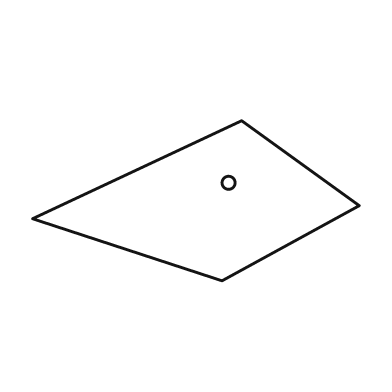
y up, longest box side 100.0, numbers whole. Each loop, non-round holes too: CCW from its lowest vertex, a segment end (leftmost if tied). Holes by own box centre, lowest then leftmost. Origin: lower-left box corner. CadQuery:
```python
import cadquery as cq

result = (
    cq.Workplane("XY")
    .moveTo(58.0, 0.0)
    .lineTo(100.0, 23.0)
    .lineTo(64.0, 49.0)
    .lineTo(0.0, 19.0)
    .close()
    .moveTo(60.0, 30.0)
    .circle(2.0)
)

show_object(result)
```